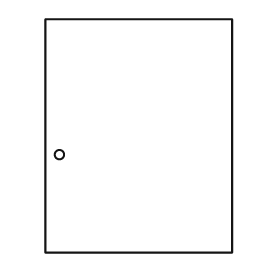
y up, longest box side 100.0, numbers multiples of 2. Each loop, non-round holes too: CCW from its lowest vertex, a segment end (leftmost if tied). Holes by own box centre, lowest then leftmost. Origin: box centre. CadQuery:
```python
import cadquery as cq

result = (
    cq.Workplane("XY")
    .moveTo(-40.0, -50.0)
    .lineTo(40.0, -50.0)
    .lineTo(40.0, 50.0)
    .lineTo(-40.0, 50.0)
    .close()
    .moveTo(-34.0, -8.0)
    .circle(2.0)
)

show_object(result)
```